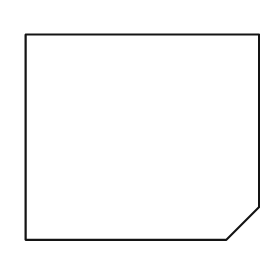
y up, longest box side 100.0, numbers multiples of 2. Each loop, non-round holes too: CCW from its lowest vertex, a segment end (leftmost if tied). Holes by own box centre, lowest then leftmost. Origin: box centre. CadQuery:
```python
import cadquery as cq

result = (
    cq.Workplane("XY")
    .moveTo(-50.0, -44.0)
    .lineTo(36.0, -44.0)
    .lineTo(50.0, -30.0)
    .lineTo(50.0, 44.0)
    .lineTo(-50.0, 44.0)
    .close()
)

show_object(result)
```